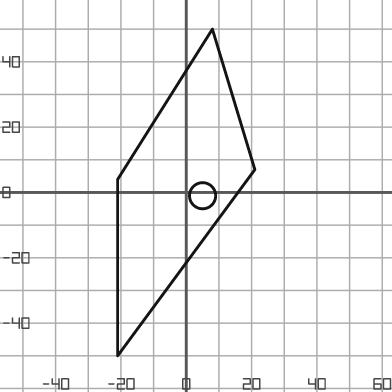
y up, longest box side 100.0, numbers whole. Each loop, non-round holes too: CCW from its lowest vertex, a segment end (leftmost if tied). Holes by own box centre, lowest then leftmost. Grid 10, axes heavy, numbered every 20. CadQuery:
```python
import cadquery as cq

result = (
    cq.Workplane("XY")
    .moveTo(-21.0, -50.0)
    .lineTo(21.0, 7.0)
    .lineTo(8.0, 50.0)
    .lineTo(-21.0, 4.0)
    .close()
    .moveTo(5.0, -1.0)
    .circle(4.0)
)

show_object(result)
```